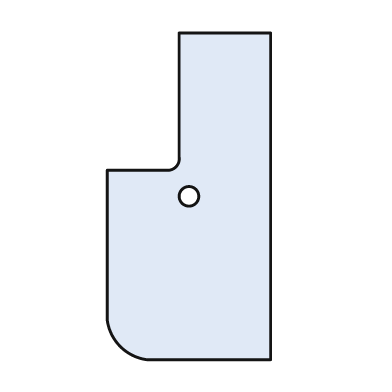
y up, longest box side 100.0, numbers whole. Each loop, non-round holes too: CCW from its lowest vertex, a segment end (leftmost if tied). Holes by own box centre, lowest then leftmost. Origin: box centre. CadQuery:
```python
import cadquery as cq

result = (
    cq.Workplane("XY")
    .moveTo(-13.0, -50.0)
    .lineTo(25.0, -50.0)
    .lineTo(25.0, 50.0)
    .lineTo(-3.0, 50.0)
    .lineTo(-3.0, 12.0)
    .threePointArc((-4.0, 9.0), (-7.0, 8.0))
    .lineTo(-25.0, 8.0)
    .lineTo(-25.0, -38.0)
    .threePointArc((-21.0, -46.0), (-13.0, -50.0))
    .close()
    .moveTo(0.0, 0.0)
    .circle(3.0)
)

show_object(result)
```